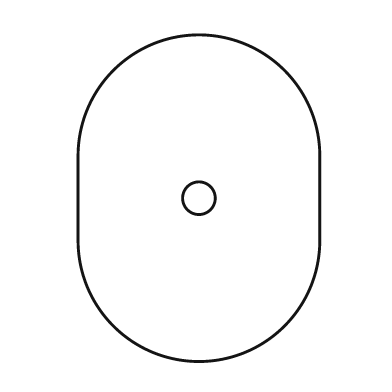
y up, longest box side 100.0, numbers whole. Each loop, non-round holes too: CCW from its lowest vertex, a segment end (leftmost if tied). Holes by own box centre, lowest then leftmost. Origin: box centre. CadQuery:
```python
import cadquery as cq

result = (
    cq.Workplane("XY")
    .moveTo(-37.0, -13.0)
    .threePointArc((0.0, -50.0), (37.0, -13.0))
    .lineTo(37.0, 13.0)
    .threePointArc((0.0, 50.0), (-37.0, 13.0))
    .close()
    .moveTo(0.0, 0.0)
    .circle(5.0)
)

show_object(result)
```